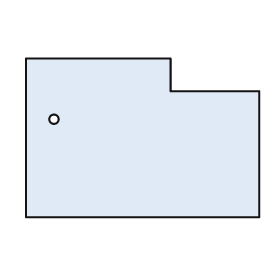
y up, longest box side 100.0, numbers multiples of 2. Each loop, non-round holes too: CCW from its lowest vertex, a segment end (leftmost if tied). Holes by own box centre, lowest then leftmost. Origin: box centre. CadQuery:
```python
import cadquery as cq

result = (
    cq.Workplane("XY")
    .moveTo(-50.0, -34.0)
    .lineTo(50.0, -34.0)
    .lineTo(50.0, 20.0)
    .lineTo(12.0, 20.0)
    .lineTo(12.0, 34.0)
    .lineTo(-50.0, 34.0)
    .close()
    .moveTo(-38.0, 8.0)
    .circle(2.0)
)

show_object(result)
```